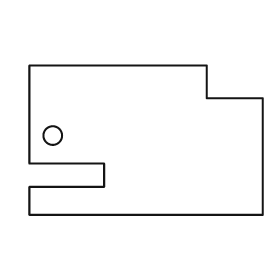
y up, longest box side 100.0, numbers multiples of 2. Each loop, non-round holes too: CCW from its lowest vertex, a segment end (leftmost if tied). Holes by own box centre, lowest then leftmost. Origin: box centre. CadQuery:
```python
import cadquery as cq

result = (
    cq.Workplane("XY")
    .moveTo(-50.0, -32.0)
    .lineTo(50.0, -32.0)
    .lineTo(50.0, 18.0)
    .lineTo(26.0, 18.0)
    .lineTo(26.0, 32.0)
    .lineTo(-50.0, 32.0)
    .lineTo(-50.0, -10.0)
    .lineTo(-18.0, -10.0)
    .lineTo(-18.0, -20.0)
    .lineTo(-50.0, -20.0)
    .close()
    .moveTo(-40.0, 2.0)
    .circle(4.0)
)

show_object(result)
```